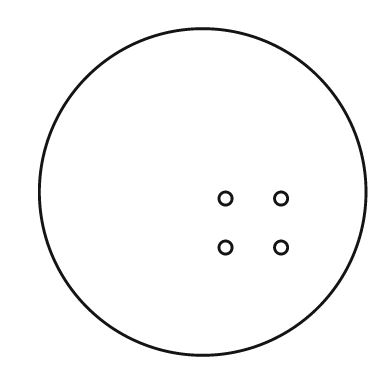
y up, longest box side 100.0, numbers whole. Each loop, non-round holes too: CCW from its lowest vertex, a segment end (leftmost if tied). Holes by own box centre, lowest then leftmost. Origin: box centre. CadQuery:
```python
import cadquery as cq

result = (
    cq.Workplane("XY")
    .moveTo(0.0, 0.0)
    .circle(50.0)
    .moveTo(7.0, -17.0)
    .circle(2.0)
    .moveTo(24.0, -17.0)
    .circle(2.0)
    .moveTo(7.0, -2.0)
    .circle(2.0)
    .moveTo(24.0, -2.0)
    .circle(2.0)
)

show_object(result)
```